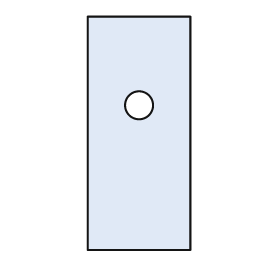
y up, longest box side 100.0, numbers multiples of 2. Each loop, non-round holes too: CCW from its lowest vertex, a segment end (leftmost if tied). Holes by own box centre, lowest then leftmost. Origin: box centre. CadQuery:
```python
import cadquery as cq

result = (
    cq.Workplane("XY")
    .moveTo(-22.0, -50.0)
    .lineTo(22.0, -50.0)
    .lineTo(22.0, 50.0)
    .lineTo(-22.0, 50.0)
    .close()
    .moveTo(0.0, 12.0)
    .circle(6.0)
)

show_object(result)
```